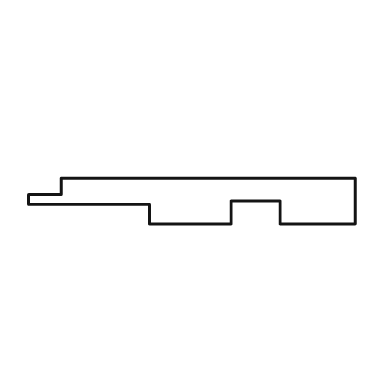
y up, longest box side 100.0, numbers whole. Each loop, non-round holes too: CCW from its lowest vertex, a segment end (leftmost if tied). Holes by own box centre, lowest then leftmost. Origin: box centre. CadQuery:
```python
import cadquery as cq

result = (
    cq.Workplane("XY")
    .moveTo(-13.0, -7.0)
    .lineTo(12.0, -7.0)
    .lineTo(12.0, 0.0)
    .lineTo(27.0, 0.0)
    .lineTo(27.0, -7.0)
    .lineTo(50.0, -7.0)
    .lineTo(50.0, 7.0)
    .lineTo(-40.0, 7.0)
    .lineTo(-40.0, 2.0)
    .lineTo(-50.0, 2.0)
    .lineTo(-50.0, -1.0)
    .lineTo(-13.0, -1.0)
    .close()
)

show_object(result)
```